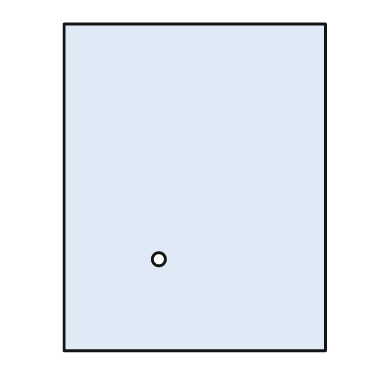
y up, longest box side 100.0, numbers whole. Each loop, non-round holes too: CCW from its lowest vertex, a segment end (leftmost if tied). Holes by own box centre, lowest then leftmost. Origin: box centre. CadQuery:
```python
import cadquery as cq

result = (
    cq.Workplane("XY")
    .moveTo(-40.0, -50.0)
    .lineTo(40.0, -50.0)
    .lineTo(40.0, 50.0)
    .lineTo(-40.0, 50.0)
    .close()
    .moveTo(-11.0, -22.0)
    .circle(2.0)
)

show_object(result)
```